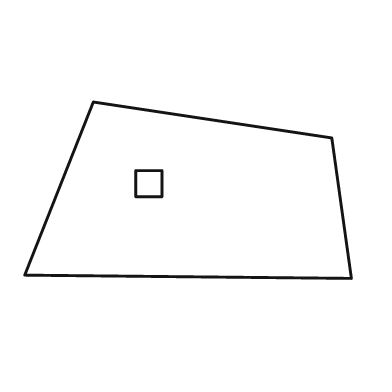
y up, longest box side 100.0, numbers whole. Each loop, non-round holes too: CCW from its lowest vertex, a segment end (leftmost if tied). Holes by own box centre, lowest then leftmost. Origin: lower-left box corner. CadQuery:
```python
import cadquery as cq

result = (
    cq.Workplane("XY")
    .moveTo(100.0, 0.0)
    .lineTo(94.0, 43.0)
    .lineTo(21.0, 54.0)
    .lineTo(0.0, 1.0)
    .close()
    .moveTo(34.0, 25.0)
    .lineTo(42.0, 25.0)
    .lineTo(42.0, 33.0)
    .lineTo(34.0, 33.0)
    .close()
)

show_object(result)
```